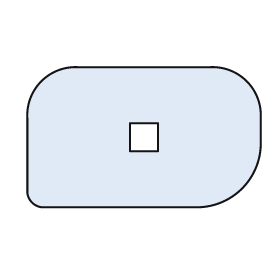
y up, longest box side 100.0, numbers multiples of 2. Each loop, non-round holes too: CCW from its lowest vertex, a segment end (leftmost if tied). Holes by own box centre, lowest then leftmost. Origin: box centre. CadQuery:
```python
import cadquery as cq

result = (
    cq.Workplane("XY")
    .moveTo(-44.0, -30.0)
    .lineTo(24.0, -30.0)
    .threePointArc((42.0, -22.0), (50.0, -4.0))
    .lineTo(50.0, 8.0)
    .threePointArc((44.0, 24.0), (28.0, 30.0))
    .lineTo(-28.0, 30.0)
    .threePointArc((-44.0, 24.0), (-50.0, 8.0))
    .lineTo(-50.0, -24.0)
    .threePointArc((-48.0, -28.0), (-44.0, -30.0))
    .close()
    .moveTo(-6.0, -6.0)
    .lineTo(6.0, -6.0)
    .lineTo(6.0, 6.0)
    .lineTo(-6.0, 6.0)
    .close()
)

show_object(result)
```